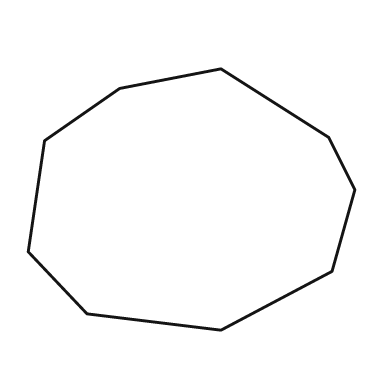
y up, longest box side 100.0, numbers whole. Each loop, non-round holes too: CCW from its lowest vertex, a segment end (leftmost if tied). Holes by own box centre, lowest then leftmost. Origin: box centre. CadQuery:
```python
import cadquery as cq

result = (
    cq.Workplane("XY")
    .moveTo(9.0, -40.0)
    .lineTo(43.0, -22.0)
    .lineTo(50.0, 3.0)
    .lineTo(42.0, 19.0)
    .lineTo(9.0, 40.0)
    .lineTo(-22.0, 34.0)
    .lineTo(-45.0, 18.0)
    .lineTo(-50.0, -16.0)
    .lineTo(-32.0, -35.0)
    .close()
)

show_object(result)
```